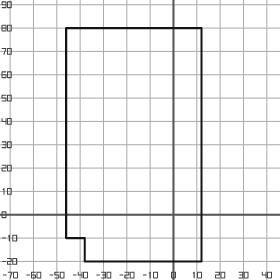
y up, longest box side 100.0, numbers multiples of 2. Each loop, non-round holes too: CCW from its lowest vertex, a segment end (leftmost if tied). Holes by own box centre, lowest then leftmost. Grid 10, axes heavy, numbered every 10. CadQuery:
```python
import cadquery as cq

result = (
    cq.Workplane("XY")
    .moveTo(-38.0, -20.0)
    .lineTo(12.0, -20.0)
    .lineTo(12.0, 80.0)
    .lineTo(-46.0, 80.0)
    .lineTo(-46.0, -10.0)
    .lineTo(-38.0, -10.0)
    .close()
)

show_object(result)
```